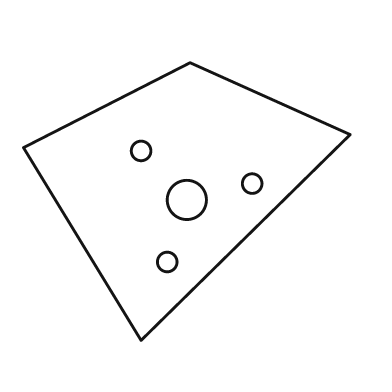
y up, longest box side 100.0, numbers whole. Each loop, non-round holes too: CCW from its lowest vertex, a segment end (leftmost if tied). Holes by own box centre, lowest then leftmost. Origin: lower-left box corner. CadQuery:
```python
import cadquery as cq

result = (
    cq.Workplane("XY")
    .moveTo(36.0, 0.0)
    .lineTo(100.0, 63.0)
    .lineTo(51.0, 85.0)
    .lineTo(0.0, 59.0)
    .close()
    .moveTo(44.0, 24.0)
    .circle(3.0)
    .moveTo(50.0, 43.0)
    .circle(6.0)
    .moveTo(70.0, 48.0)
    .circle(3.0)
    .moveTo(36.0, 58.0)
    .circle(3.0)
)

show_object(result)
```